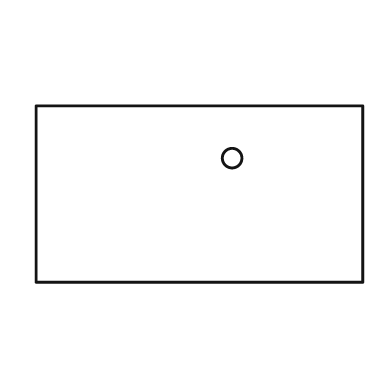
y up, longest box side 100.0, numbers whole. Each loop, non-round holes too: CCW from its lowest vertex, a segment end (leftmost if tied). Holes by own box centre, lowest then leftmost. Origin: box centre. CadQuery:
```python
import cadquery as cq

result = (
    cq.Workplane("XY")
    .moveTo(-50.0, -27.0)
    .lineTo(50.0, -27.0)
    .lineTo(50.0, 27.0)
    .lineTo(-50.0, 27.0)
    .close()
    .moveTo(10.0, 11.0)
    .circle(3.0)
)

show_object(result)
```